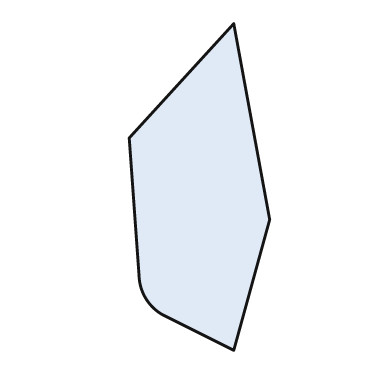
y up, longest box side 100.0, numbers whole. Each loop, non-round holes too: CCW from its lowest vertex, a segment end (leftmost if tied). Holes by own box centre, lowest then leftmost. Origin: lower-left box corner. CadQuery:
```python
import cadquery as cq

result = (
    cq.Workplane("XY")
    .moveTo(32.0, 0.0)
    .lineTo(43.0, 40.0)
    .lineTo(32.0, 100.0)
    .lineTo(0.0, 65.0)
    .lineTo(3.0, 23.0)
    .threePointArc((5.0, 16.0), (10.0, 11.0))
    .close()
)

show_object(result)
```